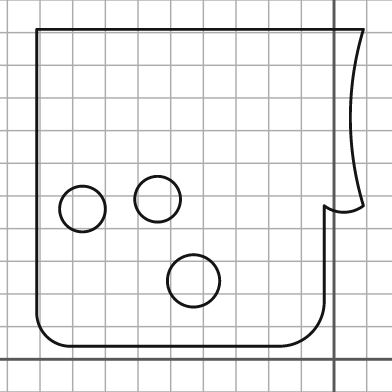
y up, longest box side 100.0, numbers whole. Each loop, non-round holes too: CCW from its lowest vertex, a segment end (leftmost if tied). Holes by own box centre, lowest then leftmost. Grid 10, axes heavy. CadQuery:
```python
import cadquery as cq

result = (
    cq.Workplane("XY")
    .moveTo(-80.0, 4.0)
    .lineTo(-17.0, 4.0)
    .threePointArc((-7.0, 8.0), (-3.0, 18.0))
    .lineTo(-3.0, 47.0)
    .threePointArc((3.0, 45.0), (9.0, 47.0))
    .threePointArc((5.0, 74.0), (9.0, 101.0))
    .lineTo(-91.0, 101.0)
    .lineTo(-91.0, 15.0)
    .threePointArc((-88.0, 7.0), (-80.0, 4.0))
    .close()
    .moveTo(-43.0, 24.0)
    .circle(8.0)
    .moveTo(-77.0, 46.0)
    .circle(7.0)
    .moveTo(-54.0, 49.0)
    .circle(7.0)
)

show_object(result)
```